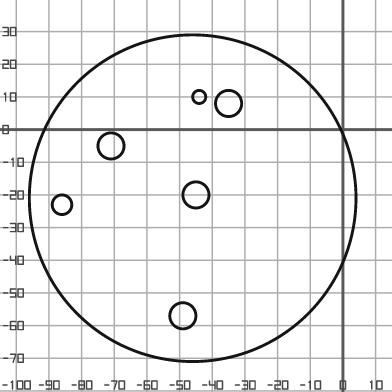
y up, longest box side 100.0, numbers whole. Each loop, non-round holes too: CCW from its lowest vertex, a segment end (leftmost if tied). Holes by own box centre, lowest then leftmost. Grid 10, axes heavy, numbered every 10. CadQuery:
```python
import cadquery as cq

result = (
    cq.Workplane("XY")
    .moveTo(-46.0, -21.0)
    .circle(50.0)
    .moveTo(-49.0, -57.0)
    .circle(4.0)
    .moveTo(-86.0, -23.0)
    .circle(3.0)
    .moveTo(-45.0, -20.0)
    .circle(4.0)
    .moveTo(-71.0, -5.0)
    .circle(4.0)
    .moveTo(-35.0, 8.0)
    .circle(4.0)
    .moveTo(-44.0, 10.0)
    .circle(2.0)
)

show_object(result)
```